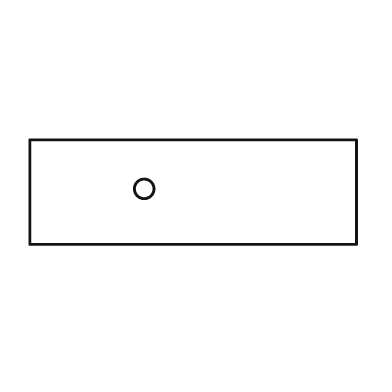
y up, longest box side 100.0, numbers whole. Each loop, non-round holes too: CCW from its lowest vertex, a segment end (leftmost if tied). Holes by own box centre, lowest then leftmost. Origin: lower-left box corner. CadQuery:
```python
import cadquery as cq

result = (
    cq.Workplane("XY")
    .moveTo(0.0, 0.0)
    .lineTo(100.0, 0.0)
    .lineTo(100.0, 32.0)
    .lineTo(0.0, 32.0)
    .close()
    .moveTo(35.0, 17.0)
    .circle(3.0)
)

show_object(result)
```